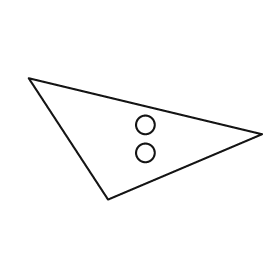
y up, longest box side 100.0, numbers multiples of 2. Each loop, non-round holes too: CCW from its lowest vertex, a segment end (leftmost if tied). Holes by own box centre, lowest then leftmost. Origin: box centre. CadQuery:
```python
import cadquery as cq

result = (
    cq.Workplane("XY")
    .moveTo(-16.0, -26.0)
    .lineTo(50.0, 2.0)
    .lineTo(-50.0, 26.0)
    .close()
    .moveTo(0.0, -6.0)
    .circle(4.0)
    .moveTo(0.0, 6.0)
    .circle(4.0)
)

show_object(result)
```